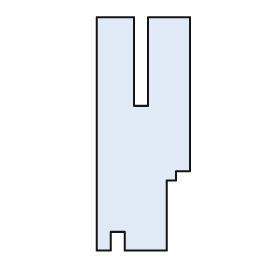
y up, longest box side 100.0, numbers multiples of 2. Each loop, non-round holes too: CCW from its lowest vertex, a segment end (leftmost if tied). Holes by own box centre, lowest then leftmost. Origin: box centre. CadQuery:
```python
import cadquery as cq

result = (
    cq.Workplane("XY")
    .moveTo(-20.0, -50.0)
    .lineTo(-14.0, -50.0)
    .lineTo(-14.0, -42.0)
    .lineTo(-8.0, -42.0)
    .lineTo(-8.0, -50.0)
    .lineTo(10.0, -50.0)
    .lineTo(10.0, -20.0)
    .lineTo(14.0, -20.0)
    .lineTo(14.0, -16.0)
    .lineTo(20.0, -16.0)
    .lineTo(20.0, 50.0)
    .lineTo(2.0, 50.0)
    .lineTo(2.0, 12.0)
    .lineTo(-4.0, 12.0)
    .lineTo(-4.0, 50.0)
    .lineTo(-20.0, 50.0)
    .close()
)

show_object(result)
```